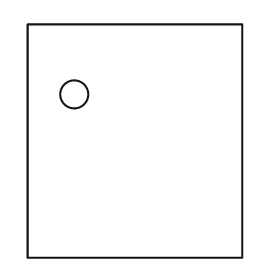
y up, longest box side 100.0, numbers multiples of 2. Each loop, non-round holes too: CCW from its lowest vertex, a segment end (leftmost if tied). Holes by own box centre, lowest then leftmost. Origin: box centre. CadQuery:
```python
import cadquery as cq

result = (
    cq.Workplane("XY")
    .moveTo(-46.0, -50.0)
    .lineTo(46.0, -50.0)
    .lineTo(46.0, 50.0)
    .lineTo(-46.0, 50.0)
    .close()
    .moveTo(-26.0, 20.0)
    .circle(6.0)
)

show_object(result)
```